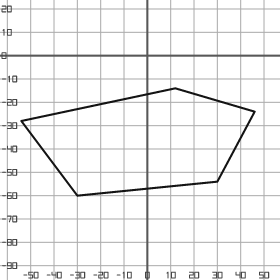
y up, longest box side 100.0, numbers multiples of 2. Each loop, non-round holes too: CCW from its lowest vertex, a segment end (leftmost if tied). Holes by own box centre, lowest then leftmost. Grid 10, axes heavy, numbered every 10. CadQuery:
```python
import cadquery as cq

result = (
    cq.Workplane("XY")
    .moveTo(-30.0, -60.0)
    .lineTo(30.0, -54.0)
    .lineTo(46.0, -24.0)
    .lineTo(12.0, -14.0)
    .lineTo(-54.0, -28.0)
    .close()
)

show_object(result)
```